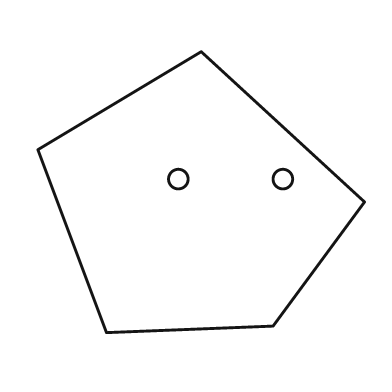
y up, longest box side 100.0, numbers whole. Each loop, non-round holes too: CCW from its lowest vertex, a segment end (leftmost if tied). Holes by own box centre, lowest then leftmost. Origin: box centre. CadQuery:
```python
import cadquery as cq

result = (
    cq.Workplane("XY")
    .moveTo(-29.0, -43.0)
    .lineTo(22.0, -41.0)
    .lineTo(50.0, -3.0)
    .lineTo(0.0, 43.0)
    .lineTo(-50.0, 13.0)
    .close()
    .moveTo(-7.0, 4.0)
    .circle(3.0)
    .moveTo(25.0, 4.0)
    .circle(3.0)
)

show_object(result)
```